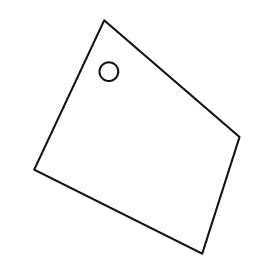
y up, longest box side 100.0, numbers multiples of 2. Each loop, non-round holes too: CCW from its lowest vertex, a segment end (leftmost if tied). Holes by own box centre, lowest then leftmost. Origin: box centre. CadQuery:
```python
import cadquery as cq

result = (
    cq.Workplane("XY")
    .moveTo(28.0, -50.0)
    .lineTo(44.0, 0.0)
    .lineTo(-14.0, 50.0)
    .lineTo(-44.0, -14.0)
    .close()
    .moveTo(-12.0, 28.0)
    .circle(4.0)
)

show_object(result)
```